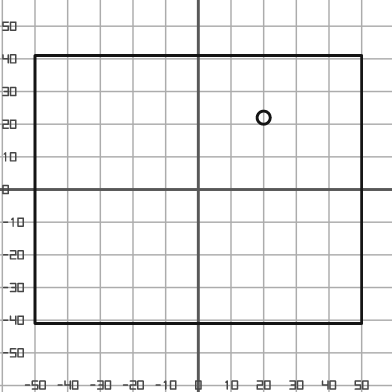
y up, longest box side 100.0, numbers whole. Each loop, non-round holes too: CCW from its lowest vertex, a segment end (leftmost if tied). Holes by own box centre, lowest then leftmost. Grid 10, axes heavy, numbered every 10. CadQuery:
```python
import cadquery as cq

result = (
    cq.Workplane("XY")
    .moveTo(-50.0, -41.0)
    .lineTo(50.0, -41.0)
    .lineTo(50.0, 41.0)
    .lineTo(-50.0, 41.0)
    .close()
    .moveTo(20.0, 22.0)
    .circle(2.0)
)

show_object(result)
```